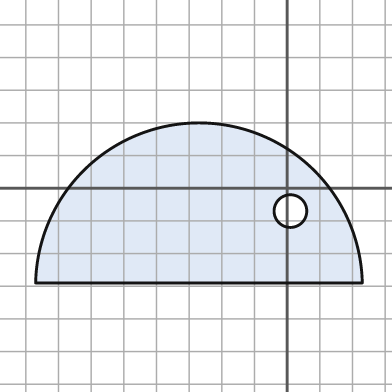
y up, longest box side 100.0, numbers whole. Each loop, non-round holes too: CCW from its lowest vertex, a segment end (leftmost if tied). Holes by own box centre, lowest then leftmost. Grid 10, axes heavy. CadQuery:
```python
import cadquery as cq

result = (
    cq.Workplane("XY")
    .moveTo(-77.0, -29.0)
    .lineTo(23.0, -29.0)
    .threePointArc((-27.0, 20.0), (-77.0, -29.0))
    .close()
    .moveTo(1.0, -7.0)
    .circle(5.0)
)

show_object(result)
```